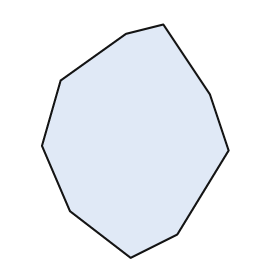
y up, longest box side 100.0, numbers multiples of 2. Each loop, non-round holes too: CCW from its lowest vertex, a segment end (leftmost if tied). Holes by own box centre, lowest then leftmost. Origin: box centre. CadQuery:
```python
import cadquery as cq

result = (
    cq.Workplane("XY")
    .moveTo(-2.0, -50.0)
    .lineTo(18.0, -40.0)
    .lineTo(40.0, -4.0)
    .lineTo(32.0, 20.0)
    .lineTo(12.0, 50.0)
    .lineTo(-4.0, 46.0)
    .lineTo(-32.0, 26.0)
    .lineTo(-40.0, -2.0)
    .lineTo(-28.0, -30.0)
    .close()
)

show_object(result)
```